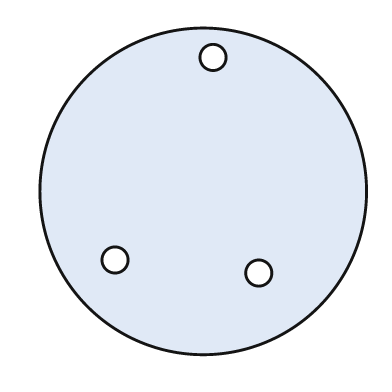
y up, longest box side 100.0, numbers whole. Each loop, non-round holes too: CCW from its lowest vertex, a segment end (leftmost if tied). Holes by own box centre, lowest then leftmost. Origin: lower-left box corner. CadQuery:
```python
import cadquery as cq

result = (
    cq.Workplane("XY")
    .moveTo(50.0, 50.0)
    .circle(50.0)
    .moveTo(67.0, 25.0)
    .circle(4.0)
    .moveTo(23.0, 29.0)
    .circle(4.0)
    .moveTo(53.0, 91.0)
    .circle(4.0)
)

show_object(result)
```